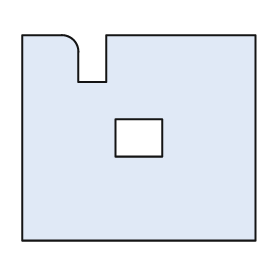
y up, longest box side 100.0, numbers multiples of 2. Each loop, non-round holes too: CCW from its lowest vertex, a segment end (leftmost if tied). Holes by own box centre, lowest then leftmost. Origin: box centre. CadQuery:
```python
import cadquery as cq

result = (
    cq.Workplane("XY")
    .moveTo(-50.0, -44.0)
    .lineTo(50.0, -44.0)
    .lineTo(50.0, 44.0)
    .lineTo(-14.0, 44.0)
    .lineTo(-14.0, 24.0)
    .lineTo(-26.0, 24.0)
    .lineTo(-26.0, 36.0)
    .threePointArc((-28.0, 42.0), (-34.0, 44.0))
    .lineTo(-50.0, 44.0)
    .close()
    .moveTo(-10.0, -8.0)
    .lineTo(10.0, -8.0)
    .lineTo(10.0, 8.0)
    .lineTo(-10.0, 8.0)
    .close()
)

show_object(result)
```